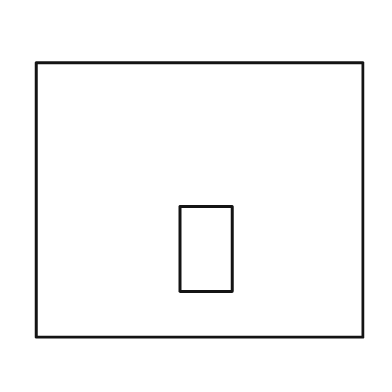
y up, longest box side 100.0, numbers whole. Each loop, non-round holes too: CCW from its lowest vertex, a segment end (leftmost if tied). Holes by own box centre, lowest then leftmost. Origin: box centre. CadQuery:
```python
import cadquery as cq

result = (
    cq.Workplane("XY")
    .moveTo(-50.0, -42.0)
    .lineTo(50.0, -42.0)
    .lineTo(50.0, 42.0)
    .lineTo(-50.0, 42.0)
    .close()
    .moveTo(-6.0, -28.0)
    .lineTo(10.0, -28.0)
    .lineTo(10.0, -2.0)
    .lineTo(-6.0, -2.0)
    .close()
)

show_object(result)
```